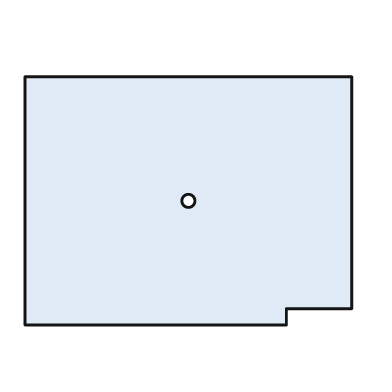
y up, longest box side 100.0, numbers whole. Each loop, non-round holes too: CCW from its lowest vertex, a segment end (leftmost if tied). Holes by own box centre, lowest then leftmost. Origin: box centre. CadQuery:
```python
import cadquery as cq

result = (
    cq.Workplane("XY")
    .moveTo(-50.0, -38.0)
    .lineTo(30.0, -38.0)
    .lineTo(30.0, -33.0)
    .lineTo(50.0, -33.0)
    .lineTo(50.0, 38.0)
    .lineTo(-50.0, 38.0)
    .close()
    .moveTo(0.0, 0.0)
    .circle(2.0)
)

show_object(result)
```